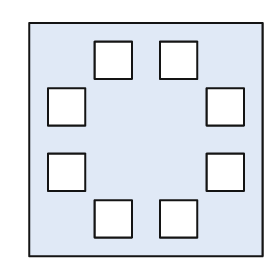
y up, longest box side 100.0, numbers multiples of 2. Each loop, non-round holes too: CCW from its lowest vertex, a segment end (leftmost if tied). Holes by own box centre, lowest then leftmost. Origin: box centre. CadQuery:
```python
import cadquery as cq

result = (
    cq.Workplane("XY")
    .moveTo(-50.0, -50.0)
    .lineTo(50.0, -50.0)
    .lineTo(50.0, 50.0)
    .lineTo(-50.0, 50.0)
    .close()
    .moveTo(-22.0, -42.0)
    .lineTo(-6.0, -42.0)
    .lineTo(-6.0, -26.0)
    .lineTo(-22.0, -26.0)
    .close()
    .moveTo(6.0, -42.0)
    .lineTo(22.0, -42.0)
    .lineTo(22.0, -26.0)
    .lineTo(6.0, -26.0)
    .close()
    .moveTo(-42.0, -22.0)
    .lineTo(-26.0, -22.0)
    .lineTo(-26.0, -6.0)
    .lineTo(-42.0, -6.0)
    .close()
    .moveTo(26.0, -22.0)
    .lineTo(42.0, -22.0)
    .lineTo(42.0, -6.0)
    .lineTo(26.0, -6.0)
    .close()
    .moveTo(-42.0, 6.0)
    .lineTo(-26.0, 6.0)
    .lineTo(-26.0, 22.0)
    .lineTo(-42.0, 22.0)
    .close()
    .moveTo(26.0, 6.0)
    .lineTo(42.0, 6.0)
    .lineTo(42.0, 22.0)
    .lineTo(26.0, 22.0)
    .close()
    .moveTo(-22.0, 26.0)
    .lineTo(-6.0, 26.0)
    .lineTo(-6.0, 42.0)
    .lineTo(-22.0, 42.0)
    .close()
    .moveTo(6.0, 26.0)
    .lineTo(22.0, 26.0)
    .lineTo(22.0, 42.0)
    .lineTo(6.0, 42.0)
    .close()
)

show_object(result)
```